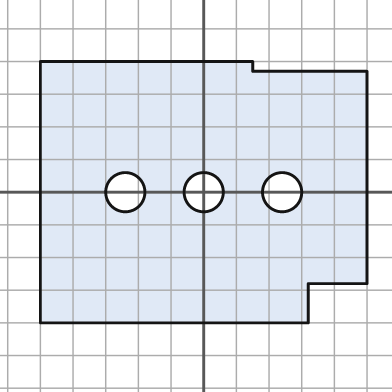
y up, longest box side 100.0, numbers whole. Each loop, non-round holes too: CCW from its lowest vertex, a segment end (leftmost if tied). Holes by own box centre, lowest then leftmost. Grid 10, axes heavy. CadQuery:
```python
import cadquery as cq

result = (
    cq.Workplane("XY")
    .moveTo(-50.0, -40.0)
    .lineTo(32.0, -40.0)
    .lineTo(32.0, -28.0)
    .lineTo(50.0, -28.0)
    .lineTo(50.0, 37.0)
    .lineTo(15.0, 37.0)
    .lineTo(15.0, 40.0)
    .lineTo(-50.0, 40.0)
    .close()
    .moveTo(-24.0, 0.0)
    .circle(6.0)
    .moveTo(0.0, 0.0)
    .circle(6.0)
    .moveTo(24.0, 0.0)
    .circle(6.0)
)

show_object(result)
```